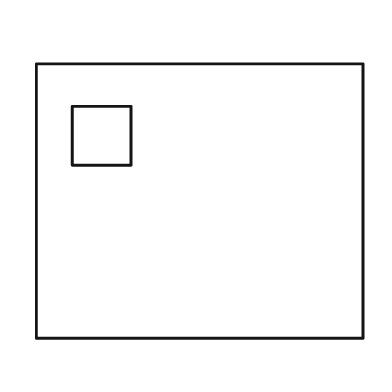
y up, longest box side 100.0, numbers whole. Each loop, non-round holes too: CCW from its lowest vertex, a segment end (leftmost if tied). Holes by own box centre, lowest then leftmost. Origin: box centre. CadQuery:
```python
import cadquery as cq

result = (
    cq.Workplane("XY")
    .moveTo(-50.0, -42.0)
    .lineTo(50.0, -42.0)
    .lineTo(50.0, 42.0)
    .lineTo(-50.0, 42.0)
    .close()
    .moveTo(-39.0, 11.0)
    .lineTo(-21.0, 11.0)
    .lineTo(-21.0, 29.0)
    .lineTo(-39.0, 29.0)
    .close()
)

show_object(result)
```